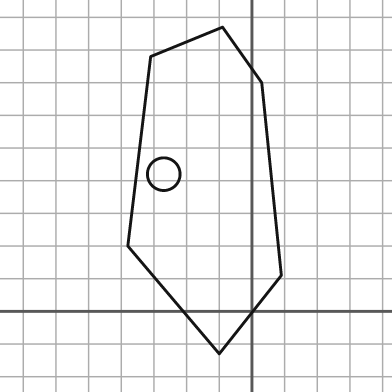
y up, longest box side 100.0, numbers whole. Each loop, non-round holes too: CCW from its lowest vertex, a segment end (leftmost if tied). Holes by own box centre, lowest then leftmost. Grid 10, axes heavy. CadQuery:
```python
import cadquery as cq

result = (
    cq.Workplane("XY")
    .moveTo(-10.0, -13.0)
    .lineTo(9.0, 11.0)
    .lineTo(3.0, 70.0)
    .lineTo(-9.0, 87.0)
    .lineTo(-31.0, 78.0)
    .lineTo(-38.0, 20.0)
    .close()
    .moveTo(-27.0, 42.0)
    .circle(5.0)
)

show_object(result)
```